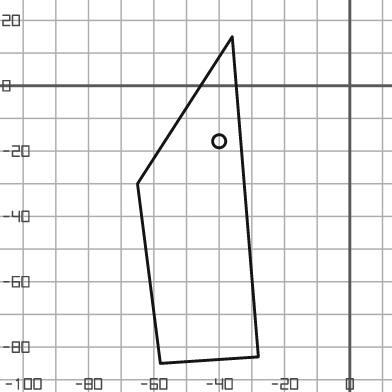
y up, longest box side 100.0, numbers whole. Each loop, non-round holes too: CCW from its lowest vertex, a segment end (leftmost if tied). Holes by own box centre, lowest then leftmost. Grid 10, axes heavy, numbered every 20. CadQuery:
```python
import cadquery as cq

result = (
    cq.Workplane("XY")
    .moveTo(-58.0, -85.0)
    .lineTo(-28.0, -83.0)
    .lineTo(-36.0, 15.0)
    .lineTo(-65.0, -30.0)
    .close()
    .moveTo(-40.0, -17.0)
    .circle(2.0)
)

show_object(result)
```